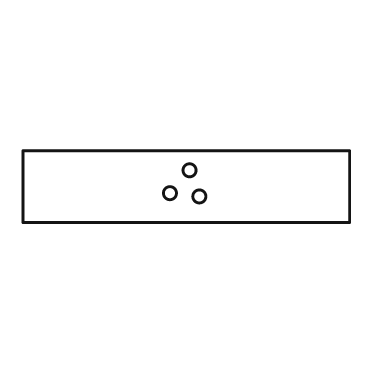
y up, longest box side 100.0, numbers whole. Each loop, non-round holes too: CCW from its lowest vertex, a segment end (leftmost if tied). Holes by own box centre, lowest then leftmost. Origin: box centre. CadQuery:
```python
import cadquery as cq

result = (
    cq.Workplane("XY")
    .moveTo(-50.0, -11.0)
    .lineTo(50.0, -11.0)
    .lineTo(50.0, 11.0)
    .lineTo(-50.0, 11.0)
    .close()
    .moveTo(4.0, -3.0)
    .circle(2.0)
    .moveTo(-5.0, -2.0)
    .circle(2.0)
    .moveTo(1.0, 5.0)
    .circle(2.0)
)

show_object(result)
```